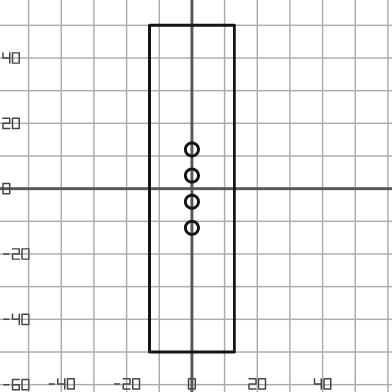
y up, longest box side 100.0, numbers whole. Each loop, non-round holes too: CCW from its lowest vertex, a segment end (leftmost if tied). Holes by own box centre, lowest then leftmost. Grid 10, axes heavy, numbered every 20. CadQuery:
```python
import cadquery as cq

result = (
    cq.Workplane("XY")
    .moveTo(-13.0, -50.0)
    .lineTo(13.0, -50.0)
    .lineTo(13.0, 50.0)
    .lineTo(-13.0, 50.0)
    .close()
    .moveTo(0.0, -12.0)
    .circle(2.0)
    .moveTo(0.0, -4.0)
    .circle(2.0)
    .moveTo(0.0, 4.0)
    .circle(2.0)
    .moveTo(0.0, 12.0)
    .circle(2.0)
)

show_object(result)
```